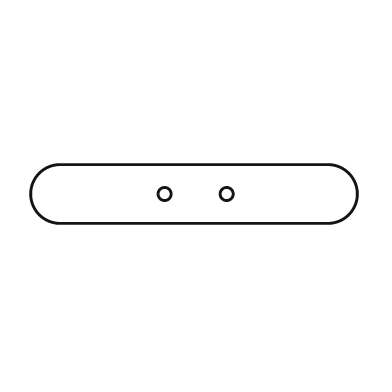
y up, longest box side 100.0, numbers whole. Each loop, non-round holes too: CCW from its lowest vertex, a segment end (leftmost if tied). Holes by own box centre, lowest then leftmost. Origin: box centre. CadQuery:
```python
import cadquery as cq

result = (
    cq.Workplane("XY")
    .moveTo(-41.0, -9.0)
    .lineTo(41.0, -9.0)
    .threePointArc((50.0, 0.0), (41.0, 9.0))
    .lineTo(-41.0, 9.0)
    .threePointArc((-50.0, 0.0), (-41.0, -9.0))
    .close()
    .moveTo(-9.0, 0.0)
    .circle(2.0)
    .moveTo(10.0, 0.0)
    .circle(2.0)
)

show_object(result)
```